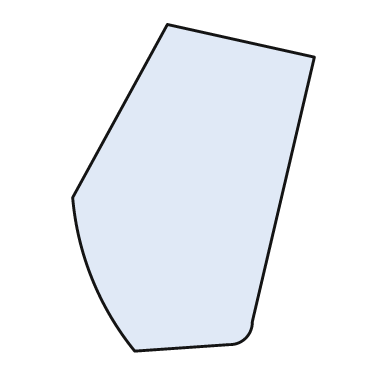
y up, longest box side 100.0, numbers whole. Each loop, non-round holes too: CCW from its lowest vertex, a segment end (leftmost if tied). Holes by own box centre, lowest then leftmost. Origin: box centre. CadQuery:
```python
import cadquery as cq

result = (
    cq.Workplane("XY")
    .moveTo(-18.0, -50.0)
    .lineTo(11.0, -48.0)
    .threePointArc((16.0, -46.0), (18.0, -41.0))
    .lineTo(37.0, 40.0)
    .lineTo(-8.0, 50.0)
    .lineTo(-37.0, -3.0)
    .threePointArc((-31.0, -28.0), (-18.0, -50.0))
    .close()
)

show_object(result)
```